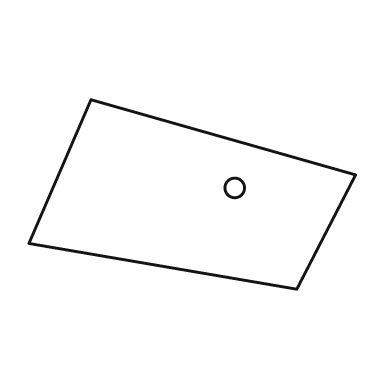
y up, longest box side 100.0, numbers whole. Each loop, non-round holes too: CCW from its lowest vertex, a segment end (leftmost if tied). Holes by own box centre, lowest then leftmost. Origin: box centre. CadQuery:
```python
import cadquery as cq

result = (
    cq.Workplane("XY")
    .moveTo(32.0, -29.0)
    .lineTo(50.0, 6.0)
    .lineTo(-31.0, 29.0)
    .lineTo(-50.0, -15.0)
    .close()
    .moveTo(13.0, 2.0)
    .circle(3.0)
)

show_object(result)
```